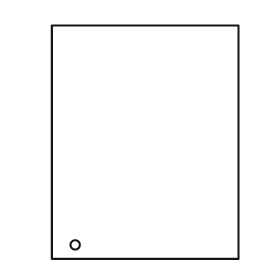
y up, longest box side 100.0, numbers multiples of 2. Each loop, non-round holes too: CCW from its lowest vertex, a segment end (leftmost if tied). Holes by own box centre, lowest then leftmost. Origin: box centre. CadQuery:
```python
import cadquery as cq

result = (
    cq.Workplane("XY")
    .moveTo(-40.0, -50.0)
    .lineTo(40.0, -50.0)
    .lineTo(40.0, 50.0)
    .lineTo(-40.0, 50.0)
    .close()
    .moveTo(-30.0, -44.0)
    .circle(2.0)
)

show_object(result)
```